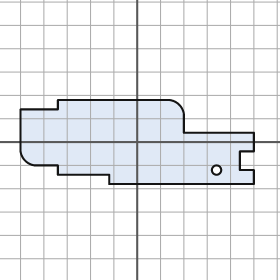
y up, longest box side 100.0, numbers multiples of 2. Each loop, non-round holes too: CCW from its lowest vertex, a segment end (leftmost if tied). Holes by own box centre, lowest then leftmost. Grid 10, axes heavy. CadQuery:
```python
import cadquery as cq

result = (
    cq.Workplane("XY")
    .moveTo(-12.0, -18.0)
    .lineTo(50.0, -18.0)
    .lineTo(50.0, -12.0)
    .lineTo(44.0, -12.0)
    .lineTo(44.0, -4.0)
    .lineTo(50.0, -4.0)
    .lineTo(50.0, 4.0)
    .lineTo(20.0, 4.0)
    .lineTo(20.0, 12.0)
    .threePointArc((18.0, 16.0), (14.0, 18.0))
    .lineTo(-34.0, 18.0)
    .lineTo(-34.0, 14.0)
    .lineTo(-50.0, 14.0)
    .lineTo(-50.0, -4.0)
    .threePointArc((-48.0, -8.0), (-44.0, -10.0))
    .lineTo(-34.0, -10.0)
    .lineTo(-34.0, -14.0)
    .lineTo(-12.0, -14.0)
    .close()
    .moveTo(34.0, -12.0)
    .circle(2.0)
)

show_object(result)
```